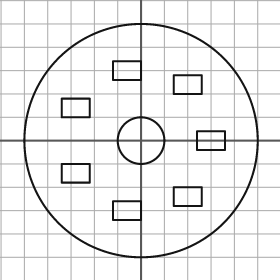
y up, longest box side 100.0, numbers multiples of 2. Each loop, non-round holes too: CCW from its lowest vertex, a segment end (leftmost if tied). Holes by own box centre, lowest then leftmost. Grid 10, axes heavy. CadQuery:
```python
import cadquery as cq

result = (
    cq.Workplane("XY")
    .moveTo(0.0, 0.0)
    .circle(50.0)
    .moveTo(-12.0, -34.0)
    .lineTo(0.0, -34.0)
    .lineTo(0.0, -26.0)
    .lineTo(-12.0, -26.0)
    .close()
    .moveTo(14.0, -28.0)
    .lineTo(26.0, -28.0)
    .lineTo(26.0, -20.0)
    .lineTo(14.0, -20.0)
    .close()
    .moveTo(-34.0, -18.0)
    .lineTo(-22.0, -18.0)
    .lineTo(-22.0, -10.0)
    .lineTo(-34.0, -10.0)
    .close()
    .moveTo(0.0, 0.0)
    .circle(10.0)
    .moveTo(24.0, -4.0)
    .lineTo(36.0, -4.0)
    .lineTo(36.0, 4.0)
    .lineTo(24.0, 4.0)
    .close()
    .moveTo(-34.0, 10.0)
    .lineTo(-22.0, 10.0)
    .lineTo(-22.0, 18.0)
    .lineTo(-34.0, 18.0)
    .close()
    .moveTo(14.0, 20.0)
    .lineTo(26.0, 20.0)
    .lineTo(26.0, 28.0)
    .lineTo(14.0, 28.0)
    .close()
    .moveTo(-12.0, 26.0)
    .lineTo(0.0, 26.0)
    .lineTo(0.0, 34.0)
    .lineTo(-12.0, 34.0)
    .close()
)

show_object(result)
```